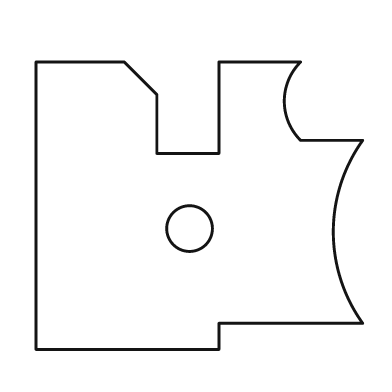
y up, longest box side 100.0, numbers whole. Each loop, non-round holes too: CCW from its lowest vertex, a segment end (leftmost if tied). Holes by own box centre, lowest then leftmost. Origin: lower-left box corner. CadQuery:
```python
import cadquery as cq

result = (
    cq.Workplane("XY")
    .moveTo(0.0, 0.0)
    .lineTo(56.0, 0.0)
    .lineTo(56.0, 8.0)
    .lineTo(100.0, 8.0)
    .threePointArc((91.0, 36.0), (100.0, 64.0))
    .lineTo(81.0, 64.0)
    .threePointArc((76.0, 76.0), (81.0, 88.0))
    .lineTo(56.0, 88.0)
    .lineTo(56.0, 60.0)
    .lineTo(37.0, 60.0)
    .lineTo(37.0, 78.0)
    .lineTo(27.0, 88.0)
    .lineTo(0.0, 88.0)
    .close()
    .moveTo(47.0, 37.0)
    .circle(7.0)
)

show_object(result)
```